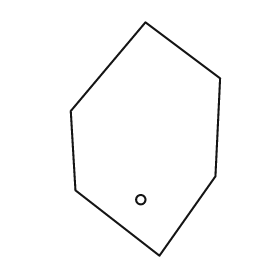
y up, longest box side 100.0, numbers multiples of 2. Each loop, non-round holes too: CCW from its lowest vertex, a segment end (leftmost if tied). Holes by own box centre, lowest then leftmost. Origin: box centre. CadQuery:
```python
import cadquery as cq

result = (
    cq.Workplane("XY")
    .moveTo(6.0, -50.0)
    .lineTo(30.0, -16.0)
    .lineTo(32.0, 26.0)
    .lineTo(0.0, 50.0)
    .lineTo(-32.0, 12.0)
    .lineTo(-30.0, -22.0)
    .close()
    .moveTo(-2.0, -26.0)
    .circle(2.0)
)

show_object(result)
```